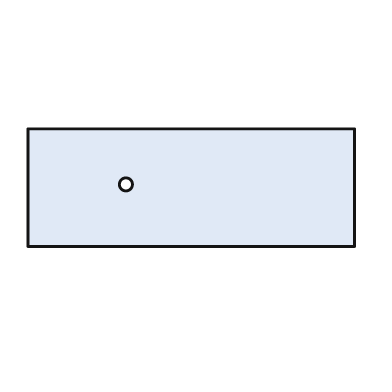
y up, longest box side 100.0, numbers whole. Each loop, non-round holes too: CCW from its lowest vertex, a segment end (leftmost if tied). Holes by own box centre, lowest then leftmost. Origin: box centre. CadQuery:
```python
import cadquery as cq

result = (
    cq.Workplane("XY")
    .moveTo(-50.0, -18.0)
    .lineTo(50.0, -18.0)
    .lineTo(50.0, 18.0)
    .lineTo(-50.0, 18.0)
    .close()
    .moveTo(-20.0, 1.0)
    .circle(2.0)
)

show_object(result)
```